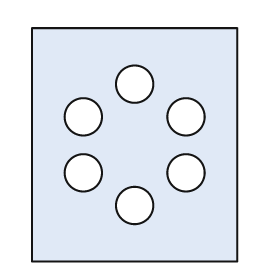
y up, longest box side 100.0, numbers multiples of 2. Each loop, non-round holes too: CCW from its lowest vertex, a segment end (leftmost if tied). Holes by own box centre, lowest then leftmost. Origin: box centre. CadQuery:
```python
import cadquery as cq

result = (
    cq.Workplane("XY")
    .moveTo(-44.0, -50.0)
    .lineTo(44.0, -50.0)
    .lineTo(44.0, 50.0)
    .lineTo(-44.0, 50.0)
    .close()
    .moveTo(0.0, -26.0)
    .circle(8.0)
    .moveTo(-22.0, -12.0)
    .circle(8.0)
    .moveTo(22.0, -12.0)
    .circle(8.0)
    .moveTo(-22.0, 12.0)
    .circle(8.0)
    .moveTo(22.0, 12.0)
    .circle(8.0)
    .moveTo(0.0, 26.0)
    .circle(8.0)
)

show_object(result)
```